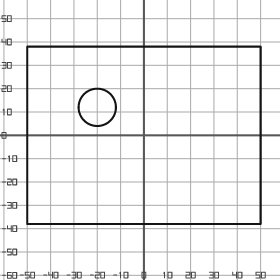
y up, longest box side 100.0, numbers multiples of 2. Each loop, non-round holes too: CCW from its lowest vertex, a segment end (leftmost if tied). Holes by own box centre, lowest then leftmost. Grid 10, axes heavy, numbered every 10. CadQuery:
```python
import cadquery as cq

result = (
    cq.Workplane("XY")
    .moveTo(-50.0, -38.0)
    .lineTo(50.0, -38.0)
    .lineTo(50.0, 38.0)
    .lineTo(-50.0, 38.0)
    .close()
    .moveTo(-20.0, 12.0)
    .circle(8.0)
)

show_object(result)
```